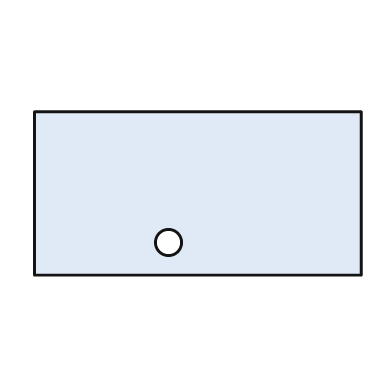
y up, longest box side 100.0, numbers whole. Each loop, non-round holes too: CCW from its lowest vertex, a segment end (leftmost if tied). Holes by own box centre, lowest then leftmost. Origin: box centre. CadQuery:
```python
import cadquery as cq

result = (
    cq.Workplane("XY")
    .moveTo(-50.0, -25.0)
    .lineTo(50.0, -25.0)
    .lineTo(50.0, 25.0)
    .lineTo(-50.0, 25.0)
    .close()
    .moveTo(-9.0, -15.0)
    .circle(4.0)
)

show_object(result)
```